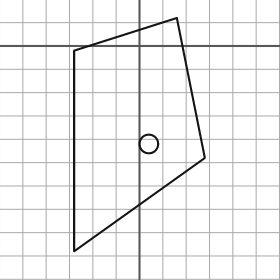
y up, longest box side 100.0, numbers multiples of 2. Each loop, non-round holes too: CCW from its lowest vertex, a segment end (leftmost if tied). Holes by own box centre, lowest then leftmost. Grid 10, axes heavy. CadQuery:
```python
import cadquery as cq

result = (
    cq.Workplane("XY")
    .moveTo(-28.0, -88.0)
    .lineTo(28.0, -48.0)
    .lineTo(16.0, 12.0)
    .lineTo(-28.0, -2.0)
    .close()
    .moveTo(4.0, -42.0)
    .circle(4.0)
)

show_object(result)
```